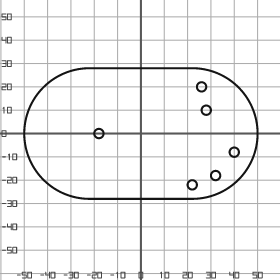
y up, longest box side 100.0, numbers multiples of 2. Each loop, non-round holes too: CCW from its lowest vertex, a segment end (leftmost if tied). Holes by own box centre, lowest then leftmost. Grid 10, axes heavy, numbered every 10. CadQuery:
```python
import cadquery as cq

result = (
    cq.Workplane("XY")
    .moveTo(-22.0, -28.0)
    .lineTo(22.0, -28.0)
    .threePointArc((50.0, 0.0), (22.0, 28.0))
    .lineTo(-22.0, 28.0)
    .threePointArc((-50.0, 0.0), (-22.0, -28.0))
    .close()
    .moveTo(22.0, -22.0)
    .circle(2.0)
    .moveTo(32.0, -18.0)
    .circle(2.0)
    .moveTo(40.0, -8.0)
    .circle(2.0)
    .moveTo(-18.0, 0.0)
    .circle(2.0)
    .moveTo(28.0, 10.0)
    .circle(2.0)
    .moveTo(26.0, 20.0)
    .circle(2.0)
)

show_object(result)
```